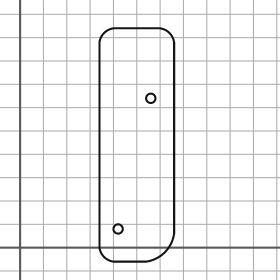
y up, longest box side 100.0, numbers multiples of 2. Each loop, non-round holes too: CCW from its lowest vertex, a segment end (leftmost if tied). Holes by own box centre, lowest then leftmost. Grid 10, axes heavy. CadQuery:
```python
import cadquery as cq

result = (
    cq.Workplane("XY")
    .moveTo(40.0, -6.0)
    .lineTo(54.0, -6.0)
    .threePointArc((62.0, -2.0), (66.0, 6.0))
    .lineTo(66.0, 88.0)
    .threePointArc((64.0, 92.0), (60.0, 94.0))
    .lineTo(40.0, 94.0)
    .threePointArc((36.0, 92.0), (34.0, 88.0))
    .lineTo(34.0, 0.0)
    .threePointArc((36.0, -4.0), (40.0, -6.0))
    .close()
    .moveTo(42.0, 8.0)
    .circle(2.0)
    .moveTo(56.0, 64.0)
    .circle(2.0)
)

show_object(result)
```